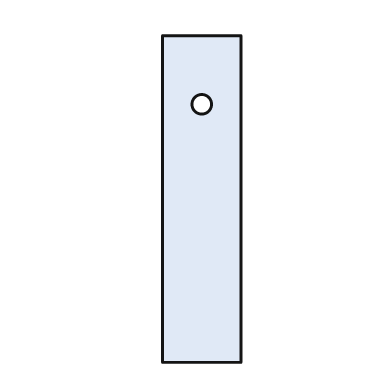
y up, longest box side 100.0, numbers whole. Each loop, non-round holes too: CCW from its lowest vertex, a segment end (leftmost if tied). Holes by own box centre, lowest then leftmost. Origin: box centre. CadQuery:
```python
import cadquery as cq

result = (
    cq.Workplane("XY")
    .moveTo(-12.0, -50.0)
    .lineTo(12.0, -50.0)
    .lineTo(12.0, 50.0)
    .lineTo(-12.0, 50.0)
    .close()
    .moveTo(0.0, 29.0)
    .circle(3.0)
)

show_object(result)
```